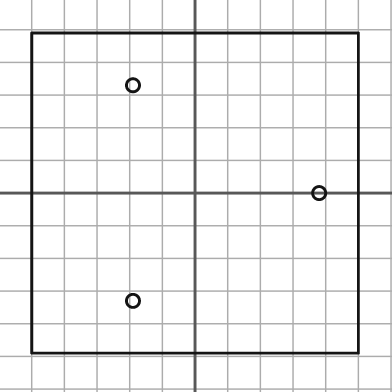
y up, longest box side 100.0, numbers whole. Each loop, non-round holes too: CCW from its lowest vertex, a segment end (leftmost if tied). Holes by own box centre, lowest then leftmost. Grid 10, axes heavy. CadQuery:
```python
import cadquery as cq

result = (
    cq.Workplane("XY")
    .moveTo(-50.0, -49.0)
    .lineTo(50.0, -49.0)
    .lineTo(50.0, 49.0)
    .lineTo(-50.0, 49.0)
    .close()
    .moveTo(-19.0, -33.0)
    .circle(2.0)
    .moveTo(38.0, 0.0)
    .circle(2.0)
    .moveTo(-19.0, 33.0)
    .circle(2.0)
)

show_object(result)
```